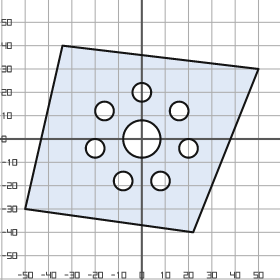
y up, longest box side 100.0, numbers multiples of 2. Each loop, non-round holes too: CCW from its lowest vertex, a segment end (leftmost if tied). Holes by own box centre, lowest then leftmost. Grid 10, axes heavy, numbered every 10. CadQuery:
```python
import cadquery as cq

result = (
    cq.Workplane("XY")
    .moveTo(22.0, -40.0)
    .lineTo(50.0, 30.0)
    .lineTo(-34.0, 40.0)
    .lineTo(-50.0, -30.0)
    .close()
    .moveTo(-8.0, -18.0)
    .circle(4.0)
    .moveTo(8.0, -18.0)
    .circle(4.0)
    .moveTo(-20.0, -4.0)
    .circle(4.0)
    .moveTo(20.0, -4.0)
    .circle(4.0)
    .moveTo(0.0, 0.0)
    .circle(8.0)
    .moveTo(-16.0, 12.0)
    .circle(4.0)
    .moveTo(16.0, 12.0)
    .circle(4.0)
    .moveTo(0.0, 20.0)
    .circle(4.0)
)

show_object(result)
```